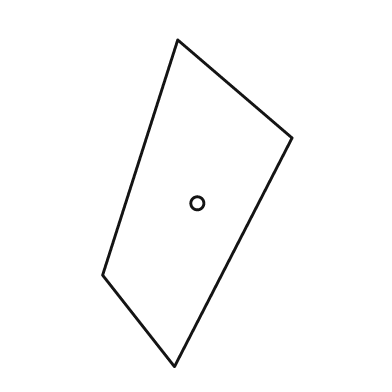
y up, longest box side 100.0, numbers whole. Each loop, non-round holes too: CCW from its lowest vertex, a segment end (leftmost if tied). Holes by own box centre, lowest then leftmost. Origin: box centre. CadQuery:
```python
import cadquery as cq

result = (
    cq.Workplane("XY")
    .moveTo(-7.0, -50.0)
    .lineTo(29.0, 20.0)
    .lineTo(-6.0, 50.0)
    .lineTo(-29.0, -22.0)
    .close()
    .moveTo(0.0, 0.0)
    .circle(2.0)
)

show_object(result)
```